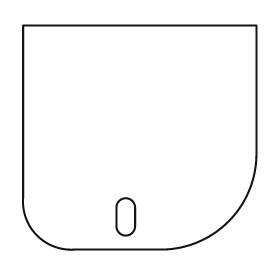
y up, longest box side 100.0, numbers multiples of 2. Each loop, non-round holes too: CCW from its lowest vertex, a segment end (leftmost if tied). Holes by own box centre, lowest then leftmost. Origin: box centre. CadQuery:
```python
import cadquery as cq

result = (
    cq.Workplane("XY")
    .moveTo(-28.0, -48.0)
    .lineTo(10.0, -48.0)
    .threePointArc((38.0, -36.0), (50.0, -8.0))
    .lineTo(50.0, 48.0)
    .lineTo(-50.0, 48.0)
    .lineTo(-50.0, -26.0)
    .threePointArc((-44.0, -42.0), (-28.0, -48.0))
    .close()
    .moveTo(-10.0, -38.0)
    .threePointArc((-6.0, -42.0), (-2.0, -38.0))
    .lineTo(-2.0, -30.0)
    .threePointArc((-6.0, -26.0), (-10.0, -30.0))
    .close()
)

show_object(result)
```